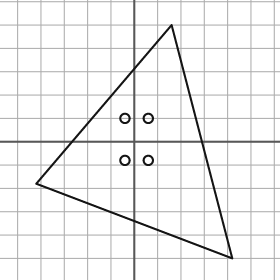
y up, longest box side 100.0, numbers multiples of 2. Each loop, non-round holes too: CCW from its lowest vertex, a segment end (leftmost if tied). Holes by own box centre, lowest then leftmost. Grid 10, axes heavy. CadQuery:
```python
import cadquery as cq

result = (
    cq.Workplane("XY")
    .moveTo(42.0, -50.0)
    .lineTo(16.0, 50.0)
    .lineTo(-42.0, -18.0)
    .close()
    .moveTo(-4.0, -8.0)
    .circle(2.0)
    .moveTo(6.0, -8.0)
    .circle(2.0)
    .moveTo(-4.0, 10.0)
    .circle(2.0)
    .moveTo(6.0, 10.0)
    .circle(2.0)
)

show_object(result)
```